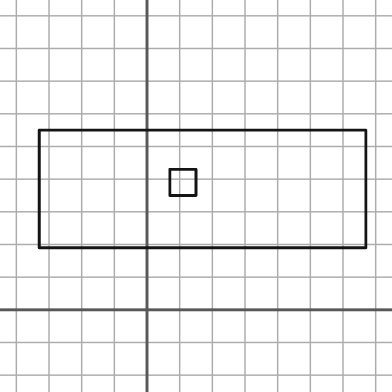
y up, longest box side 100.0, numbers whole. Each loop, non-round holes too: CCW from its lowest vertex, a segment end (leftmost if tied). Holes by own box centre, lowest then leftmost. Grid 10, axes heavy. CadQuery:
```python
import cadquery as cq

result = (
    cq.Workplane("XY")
    .moveTo(-33.0, 19.0)
    .lineTo(67.0, 19.0)
    .lineTo(67.0, 55.0)
    .lineTo(-33.0, 55.0)
    .close()
    .moveTo(7.0, 35.0)
    .lineTo(15.0, 35.0)
    .lineTo(15.0, 43.0)
    .lineTo(7.0, 43.0)
    .close()
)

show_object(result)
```